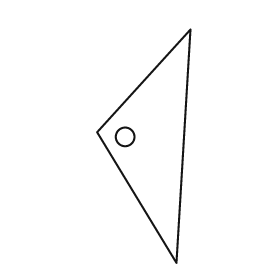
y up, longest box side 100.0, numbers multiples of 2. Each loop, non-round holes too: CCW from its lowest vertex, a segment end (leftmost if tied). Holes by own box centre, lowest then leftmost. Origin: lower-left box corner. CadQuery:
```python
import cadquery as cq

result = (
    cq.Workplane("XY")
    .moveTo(34.0, 0.0)
    .lineTo(40.0, 100.0)
    .lineTo(0.0, 56.0)
    .close()
    .moveTo(12.0, 54.0)
    .circle(4.0)
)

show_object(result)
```